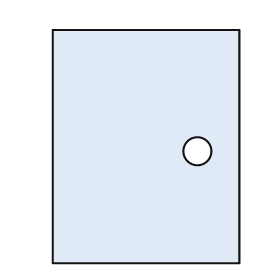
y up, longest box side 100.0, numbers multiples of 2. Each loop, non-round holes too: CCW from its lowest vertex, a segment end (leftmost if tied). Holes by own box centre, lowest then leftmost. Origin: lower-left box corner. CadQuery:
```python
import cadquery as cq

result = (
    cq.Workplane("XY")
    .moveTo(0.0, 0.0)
    .lineTo(80.0, 0.0)
    .lineTo(80.0, 100.0)
    .lineTo(0.0, 100.0)
    .close()
    .moveTo(62.0, 48.0)
    .circle(6.0)
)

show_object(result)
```